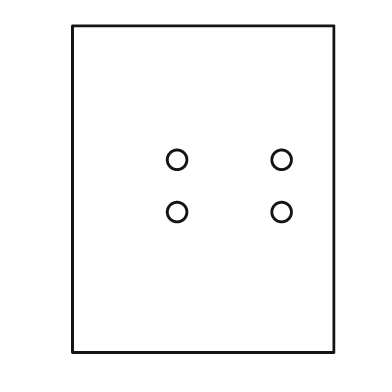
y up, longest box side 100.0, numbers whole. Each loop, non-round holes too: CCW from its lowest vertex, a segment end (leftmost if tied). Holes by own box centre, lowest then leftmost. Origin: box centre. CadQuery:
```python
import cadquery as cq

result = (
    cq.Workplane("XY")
    .moveTo(-40.0, -50.0)
    .lineTo(40.0, -50.0)
    .lineTo(40.0, 50.0)
    .lineTo(-40.0, 50.0)
    .close()
    .moveTo(-8.0, -7.0)
    .circle(3.0)
    .moveTo(24.0, -7.0)
    .circle(3.0)
    .moveTo(-8.0, 9.0)
    .circle(3.0)
    .moveTo(24.0, 9.0)
    .circle(3.0)
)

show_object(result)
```